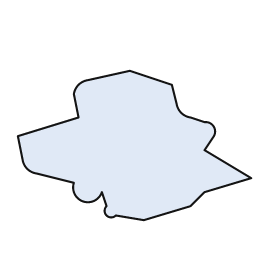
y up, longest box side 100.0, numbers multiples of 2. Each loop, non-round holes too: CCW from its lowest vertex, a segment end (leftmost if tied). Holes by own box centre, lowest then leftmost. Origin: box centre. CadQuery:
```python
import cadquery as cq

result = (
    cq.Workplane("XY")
    .moveTo(4.0, -32.0)
    .lineTo(24.0, -26.0)
    .lineTo(30.0, -20.0)
    .lineTo(50.0, -14.0)
    .lineTo(30.0, -2.0)
    .lineTo(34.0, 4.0)
    .threePointArc((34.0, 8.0), (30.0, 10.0))
    .lineTo(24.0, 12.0)
    .threePointArc((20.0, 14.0), (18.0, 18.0))
    .lineTo(16.0, 26.0)
    .lineTo(-2.0, 32.0)
    .lineTo(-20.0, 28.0)
    .threePointArc((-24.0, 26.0), (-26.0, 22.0))
    .lineTo(-24.0, 12.0)
    .lineTo(-50.0, 4.0)
    .lineTo(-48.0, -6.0)
    .threePointArc((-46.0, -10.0), (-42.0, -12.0))
    .lineTo(-26.0, -16.0)
    .threePointArc((-22.0, -24.0), (-14.0, -20.0))
    .lineTo(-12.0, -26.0)
    .threePointArc((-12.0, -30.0), (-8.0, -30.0))
    .close()
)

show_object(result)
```